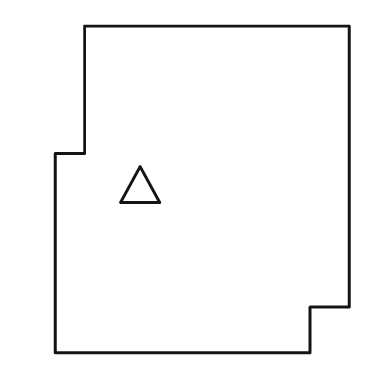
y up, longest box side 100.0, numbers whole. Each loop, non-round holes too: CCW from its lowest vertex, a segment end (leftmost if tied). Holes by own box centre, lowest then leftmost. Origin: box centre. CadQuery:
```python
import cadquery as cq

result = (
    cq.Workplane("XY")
    .moveTo(-45.0, -50.0)
    .lineTo(33.0, -50.0)
    .lineTo(33.0, -36.0)
    .lineTo(45.0, -36.0)
    .lineTo(45.0, 50.0)
    .lineTo(-36.0, 50.0)
    .lineTo(-36.0, 11.0)
    .lineTo(-45.0, 11.0)
    .close()
    .moveTo(-25.0, -4.0)
    .lineTo(-13.0, -4.0)
    .lineTo(-19.0, 7.0)
    .close()
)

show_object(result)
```